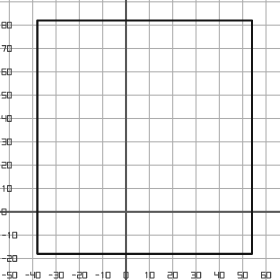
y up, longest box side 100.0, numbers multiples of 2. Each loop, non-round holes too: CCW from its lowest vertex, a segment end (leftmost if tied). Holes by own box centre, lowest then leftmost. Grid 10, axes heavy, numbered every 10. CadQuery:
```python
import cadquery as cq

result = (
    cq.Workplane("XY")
    .moveTo(-38.0, -18.0)
    .lineTo(54.0, -18.0)
    .lineTo(54.0, 82.0)
    .lineTo(-38.0, 82.0)
    .close()
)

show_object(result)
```